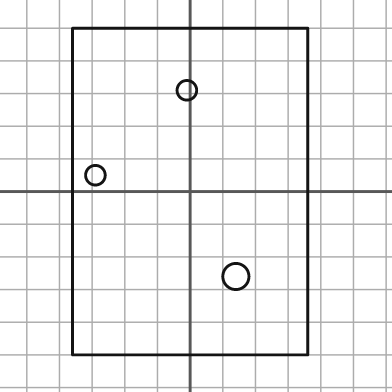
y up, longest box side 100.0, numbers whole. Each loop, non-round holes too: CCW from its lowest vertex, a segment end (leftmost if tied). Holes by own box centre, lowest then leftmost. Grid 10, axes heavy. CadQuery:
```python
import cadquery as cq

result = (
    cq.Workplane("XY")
    .moveTo(-36.0, -50.0)
    .lineTo(36.0, -50.0)
    .lineTo(36.0, 50.0)
    .lineTo(-36.0, 50.0)
    .close()
    .moveTo(14.0, -26.0)
    .circle(4.0)
    .moveTo(-29.0, 5.0)
    .circle(3.0)
    .moveTo(-1.0, 31.0)
    .circle(3.0)
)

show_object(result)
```